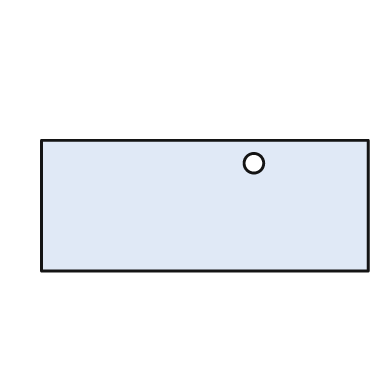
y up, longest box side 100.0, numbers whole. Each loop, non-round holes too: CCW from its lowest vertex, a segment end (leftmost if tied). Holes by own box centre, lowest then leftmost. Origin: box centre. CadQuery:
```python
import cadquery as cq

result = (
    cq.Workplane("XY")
    .moveTo(-50.0, -20.0)
    .lineTo(50.0, -20.0)
    .lineTo(50.0, 20.0)
    .lineTo(-50.0, 20.0)
    .close()
    .moveTo(15.0, 13.0)
    .circle(3.0)
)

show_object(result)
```